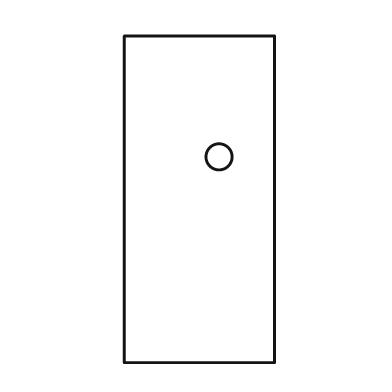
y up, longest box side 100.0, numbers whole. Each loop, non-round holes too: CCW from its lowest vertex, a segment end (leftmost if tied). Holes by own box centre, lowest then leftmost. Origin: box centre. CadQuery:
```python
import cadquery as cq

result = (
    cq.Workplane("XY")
    .moveTo(-23.0, -50.0)
    .lineTo(23.0, -50.0)
    .lineTo(23.0, 50.0)
    .lineTo(-23.0, 50.0)
    .close()
    .moveTo(6.0, 13.0)
    .circle(4.0)
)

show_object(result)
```